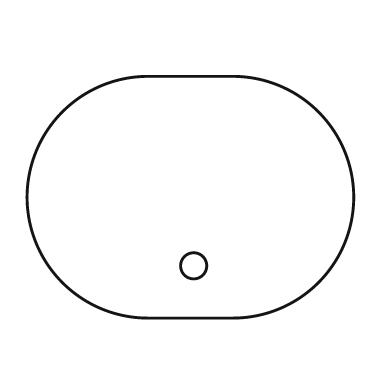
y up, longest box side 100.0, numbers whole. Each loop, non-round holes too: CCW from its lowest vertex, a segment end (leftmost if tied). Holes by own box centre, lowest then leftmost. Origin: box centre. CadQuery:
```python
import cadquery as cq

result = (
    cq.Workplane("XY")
    .moveTo(-13.0, -37.0)
    .lineTo(13.0, -37.0)
    .threePointArc((50.0, 0.0), (13.0, 37.0))
    .lineTo(-13.0, 37.0)
    .threePointArc((-50.0, 0.0), (-13.0, -37.0))
    .close()
    .moveTo(1.0, -21.0)
    .circle(4.0)
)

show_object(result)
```